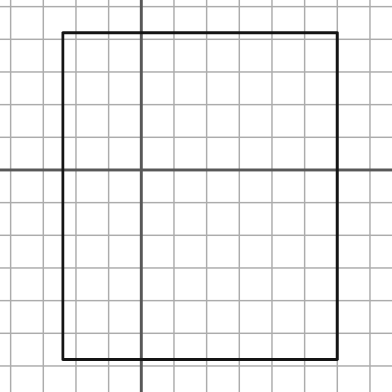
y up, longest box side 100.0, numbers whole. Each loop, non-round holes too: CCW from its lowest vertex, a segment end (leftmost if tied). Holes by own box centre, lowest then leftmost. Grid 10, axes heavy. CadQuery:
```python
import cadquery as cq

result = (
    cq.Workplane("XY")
    .moveTo(-24.0, -58.0)
    .lineTo(60.0, -58.0)
    .lineTo(60.0, 42.0)
    .lineTo(-24.0, 42.0)
    .close()
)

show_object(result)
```